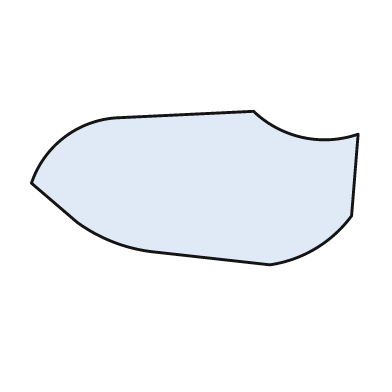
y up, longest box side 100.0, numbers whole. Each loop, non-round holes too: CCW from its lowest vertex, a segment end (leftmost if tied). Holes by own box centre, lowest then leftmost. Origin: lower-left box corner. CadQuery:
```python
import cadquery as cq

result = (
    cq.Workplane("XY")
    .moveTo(73.0, 0.0)
    .threePointArc((87.0, 5.0), (98.0, 15.0))
    .lineTo(100.0, 40.0)
    .threePointArc((83.0, 39.0), (68.0, 47.0))
    .lineTo(26.0, 45.0)
    .threePointArc((10.0, 39.0), (0.0, 25.0))
    .lineTo(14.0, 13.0)
    .threePointArc((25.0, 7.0), (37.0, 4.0))
    .close()
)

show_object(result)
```